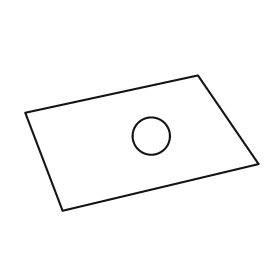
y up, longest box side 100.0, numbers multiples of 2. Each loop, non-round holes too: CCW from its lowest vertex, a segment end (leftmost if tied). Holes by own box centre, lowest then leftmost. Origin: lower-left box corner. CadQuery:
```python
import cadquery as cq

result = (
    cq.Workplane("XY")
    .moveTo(16.0, 0.0)
    .lineTo(100.0, 20.0)
    .lineTo(74.0, 58.0)
    .lineTo(0.0, 42.0)
    .close()
    .moveTo(54.0, 32.0)
    .circle(8.0)
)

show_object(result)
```